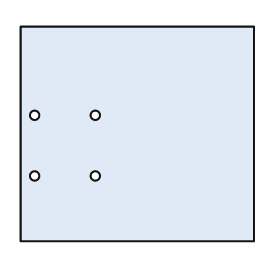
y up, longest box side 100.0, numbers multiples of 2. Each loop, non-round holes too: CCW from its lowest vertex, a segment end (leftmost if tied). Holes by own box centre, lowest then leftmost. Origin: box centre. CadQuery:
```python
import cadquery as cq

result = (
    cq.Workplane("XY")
    .moveTo(-50.0, -46.0)
    .lineTo(50.0, -46.0)
    .lineTo(50.0, 46.0)
    .lineTo(-50.0, 46.0)
    .close()
    .moveTo(-44.0, -18.0)
    .circle(2.0)
    .moveTo(-18.0, -18.0)
    .circle(2.0)
    .moveTo(-44.0, 8.0)
    .circle(2.0)
    .moveTo(-18.0, 8.0)
    .circle(2.0)
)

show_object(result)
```